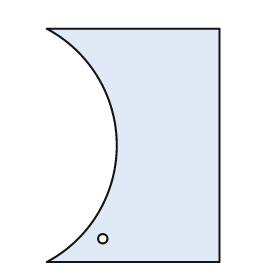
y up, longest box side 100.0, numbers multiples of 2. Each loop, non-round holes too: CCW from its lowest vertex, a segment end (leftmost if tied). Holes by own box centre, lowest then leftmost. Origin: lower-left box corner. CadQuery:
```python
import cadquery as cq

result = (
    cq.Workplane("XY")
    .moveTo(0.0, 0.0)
    .lineTo(74.0, 0.0)
    .lineTo(74.0, 100.0)
    .lineTo(0.0, 100.0)
    .threePointArc((30.0, 50.0), (0.0, 0.0))
    .close()
    .moveTo(24.0, 10.0)
    .circle(2.0)
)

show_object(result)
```